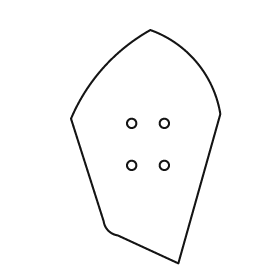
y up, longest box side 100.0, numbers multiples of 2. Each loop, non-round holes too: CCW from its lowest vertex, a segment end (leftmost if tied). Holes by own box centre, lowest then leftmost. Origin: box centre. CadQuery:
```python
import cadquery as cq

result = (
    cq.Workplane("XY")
    .moveTo(14.0, -50.0)
    .lineTo(32.0, 14.0)
    .threePointArc((22.0, 36.0), (2.0, 50.0))
    .threePointArc((-18.0, 34.0), (-32.0, 12.0))
    .lineTo(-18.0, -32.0)
    .threePointArc((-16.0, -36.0), (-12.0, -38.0))
    .close()
    .moveTo(-6.0, -8.0)
    .circle(2.0)
    .moveTo(8.0, -8.0)
    .circle(2.0)
    .moveTo(-6.0, 10.0)
    .circle(2.0)
    .moveTo(8.0, 10.0)
    .circle(2.0)
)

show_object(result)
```